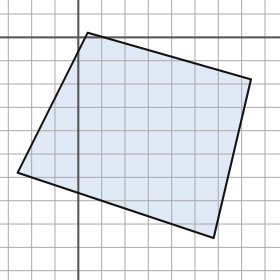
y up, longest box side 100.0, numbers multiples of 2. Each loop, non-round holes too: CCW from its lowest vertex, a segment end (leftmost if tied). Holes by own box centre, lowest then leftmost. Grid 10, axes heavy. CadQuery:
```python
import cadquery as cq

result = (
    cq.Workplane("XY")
    .moveTo(58.0, -86.0)
    .lineTo(74.0, -18.0)
    .lineTo(4.0, 2.0)
    .lineTo(-26.0, -58.0)
    .close()
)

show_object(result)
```